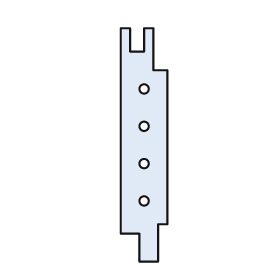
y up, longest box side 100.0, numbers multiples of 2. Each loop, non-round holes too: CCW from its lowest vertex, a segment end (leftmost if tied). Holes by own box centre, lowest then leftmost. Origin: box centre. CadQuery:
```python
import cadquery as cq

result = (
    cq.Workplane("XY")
    .moveTo(-2.0, -50.0)
    .lineTo(6.0, -50.0)
    .lineTo(6.0, -34.0)
    .lineTo(10.0, -34.0)
    .lineTo(10.0, 32.0)
    .lineTo(4.0, 32.0)
    .lineTo(4.0, 50.0)
    .lineTo(0.0, 50.0)
    .lineTo(0.0, 40.0)
    .lineTo(-6.0, 40.0)
    .lineTo(-6.0, 50.0)
    .lineTo(-10.0, 50.0)
    .lineTo(-10.0, -38.0)
    .lineTo(-2.0, -38.0)
    .close()
    .moveTo(0.0, -24.0)
    .circle(2.0)
    .moveTo(0.0, -8.0)
    .circle(2.0)
    .moveTo(0.0, 8.0)
    .circle(2.0)
    .moveTo(0.0, 24.0)
    .circle(2.0)
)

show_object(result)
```